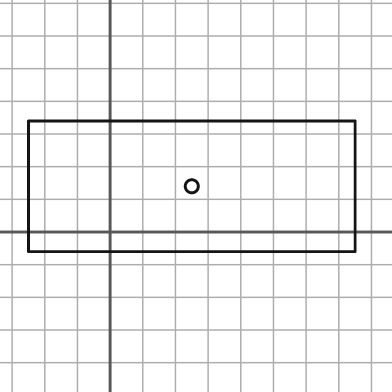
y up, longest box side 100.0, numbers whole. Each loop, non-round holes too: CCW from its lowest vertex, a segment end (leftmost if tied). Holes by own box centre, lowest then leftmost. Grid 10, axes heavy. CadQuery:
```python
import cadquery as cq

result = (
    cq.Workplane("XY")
    .moveTo(-25.0, -6.0)
    .lineTo(75.0, -6.0)
    .lineTo(75.0, 34.0)
    .lineTo(-25.0, 34.0)
    .close()
    .moveTo(25.0, 14.0)
    .circle(2.0)
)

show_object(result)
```